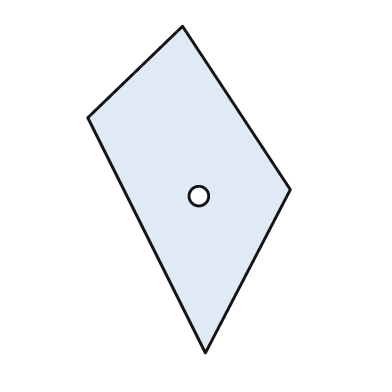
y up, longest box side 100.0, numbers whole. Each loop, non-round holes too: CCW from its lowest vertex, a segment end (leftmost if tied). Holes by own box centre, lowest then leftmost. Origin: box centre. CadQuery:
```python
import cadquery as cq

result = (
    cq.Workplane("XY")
    .moveTo(5.0, -50.0)
    .lineTo(31.0, 0.0)
    .lineTo(-2.0, 50.0)
    .lineTo(-31.0, 22.0)
    .close()
    .moveTo(3.0, -2.0)
    .circle(3.0)
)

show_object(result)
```